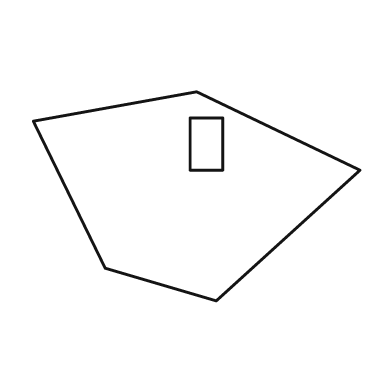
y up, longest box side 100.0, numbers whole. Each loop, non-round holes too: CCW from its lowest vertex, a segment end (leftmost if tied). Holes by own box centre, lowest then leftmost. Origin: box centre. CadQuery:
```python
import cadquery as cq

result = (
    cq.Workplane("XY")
    .moveTo(6.0, -32.0)
    .lineTo(50.0, 8.0)
    .lineTo(0.0, 32.0)
    .lineTo(-50.0, 23.0)
    .lineTo(-28.0, -22.0)
    .close()
    .moveTo(-2.0, 8.0)
    .lineTo(8.0, 8.0)
    .lineTo(8.0, 24.0)
    .lineTo(-2.0, 24.0)
    .close()
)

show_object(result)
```